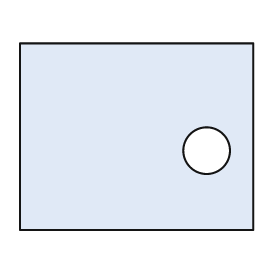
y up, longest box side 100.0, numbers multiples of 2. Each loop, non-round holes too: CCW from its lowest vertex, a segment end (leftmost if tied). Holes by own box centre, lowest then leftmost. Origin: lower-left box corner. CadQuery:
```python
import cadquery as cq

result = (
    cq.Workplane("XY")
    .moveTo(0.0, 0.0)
    .lineTo(100.0, 0.0)
    .lineTo(100.0, 80.0)
    .lineTo(0.0, 80.0)
    .close()
    .moveTo(80.0, 34.0)
    .circle(10.0)
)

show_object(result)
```